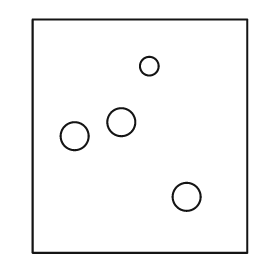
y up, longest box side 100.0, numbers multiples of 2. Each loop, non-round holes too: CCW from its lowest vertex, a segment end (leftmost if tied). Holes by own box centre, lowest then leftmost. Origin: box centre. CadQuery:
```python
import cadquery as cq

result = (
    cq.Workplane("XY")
    .moveTo(-46.0, -50.0)
    .lineTo(46.0, -50.0)
    .lineTo(46.0, 50.0)
    .lineTo(-46.0, 50.0)
    .close()
    .moveTo(20.0, -26.0)
    .circle(6.0)
    .moveTo(-28.0, 0.0)
    .circle(6.0)
    .moveTo(-8.0, 6.0)
    .circle(6.0)
    .moveTo(4.0, 30.0)
    .circle(4.0)
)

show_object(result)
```